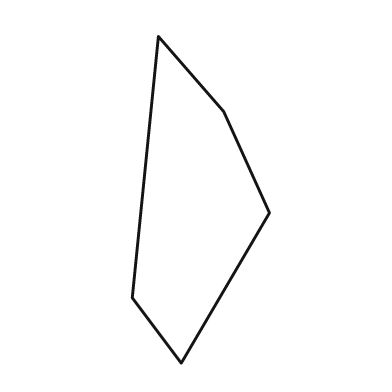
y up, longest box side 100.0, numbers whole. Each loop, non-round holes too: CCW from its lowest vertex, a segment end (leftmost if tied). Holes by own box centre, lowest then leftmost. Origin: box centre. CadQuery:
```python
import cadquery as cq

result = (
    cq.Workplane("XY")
    .moveTo(-6.0, -50.0)
    .lineTo(21.0, -4.0)
    .lineTo(7.0, 27.0)
    .lineTo(-13.0, 50.0)
    .lineTo(-21.0, -30.0)
    .close()
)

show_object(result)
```